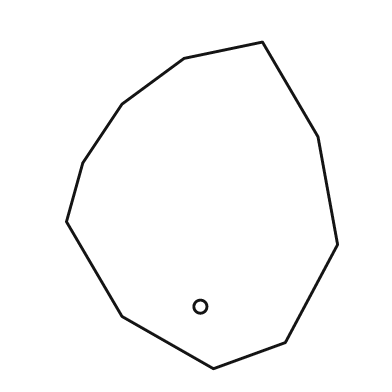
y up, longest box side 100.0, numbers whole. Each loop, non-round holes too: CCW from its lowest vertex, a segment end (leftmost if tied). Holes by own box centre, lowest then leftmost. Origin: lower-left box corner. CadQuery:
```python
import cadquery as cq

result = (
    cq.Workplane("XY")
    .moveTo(45.0, 0.0)
    .lineTo(67.0, 8.0)
    .lineTo(83.0, 38.0)
    .lineTo(77.0, 71.0)
    .lineTo(60.0, 100.0)
    .lineTo(36.0, 95.0)
    .lineTo(17.0, 81.0)
    .lineTo(5.0, 63.0)
    .lineTo(0.0, 45.0)
    .lineTo(17.0, 16.0)
    .close()
    .moveTo(41.0, 19.0)
    .circle(2.0)
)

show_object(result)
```